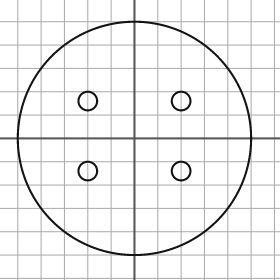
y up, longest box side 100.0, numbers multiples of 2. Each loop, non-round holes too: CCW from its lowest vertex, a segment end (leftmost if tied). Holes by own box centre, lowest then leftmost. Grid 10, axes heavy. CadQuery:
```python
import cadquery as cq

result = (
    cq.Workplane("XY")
    .moveTo(0.0, 0.0)
    .circle(50.0)
    .moveTo(-20.0, -14.0)
    .circle(4.0)
    .moveTo(20.0, -14.0)
    .circle(4.0)
    .moveTo(-20.0, 16.0)
    .circle(4.0)
    .moveTo(20.0, 16.0)
    .circle(4.0)
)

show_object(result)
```